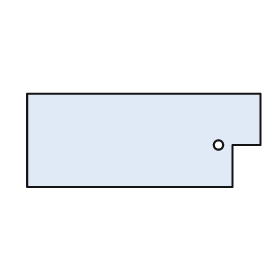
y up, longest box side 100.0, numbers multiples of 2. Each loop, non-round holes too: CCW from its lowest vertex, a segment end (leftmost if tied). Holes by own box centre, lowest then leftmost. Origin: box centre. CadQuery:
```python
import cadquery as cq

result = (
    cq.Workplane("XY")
    .moveTo(-50.0, -20.0)
    .lineTo(38.0, -20.0)
    .lineTo(38.0, -2.0)
    .lineTo(50.0, -2.0)
    .lineTo(50.0, 20.0)
    .lineTo(-50.0, 20.0)
    .close()
    .moveTo(32.0, -2.0)
    .circle(2.0)
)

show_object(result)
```